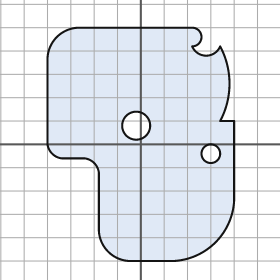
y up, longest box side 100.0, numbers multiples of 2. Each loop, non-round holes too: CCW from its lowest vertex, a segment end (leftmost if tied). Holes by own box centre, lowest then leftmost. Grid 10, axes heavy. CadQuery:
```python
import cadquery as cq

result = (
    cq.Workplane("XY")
    .moveTo(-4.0, -50.0)
    .lineTo(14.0, -50.0)
    .threePointArc((32.0, -42.0), (40.0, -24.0))
    .lineTo(40.0, 10.0)
    .lineTo(34.0, 10.0)
    .threePointArc((38.0, 26.0), (34.0, 42.0))
    .threePointArc((28.0, 38.0), (22.0, 42.0))
    .threePointArc((26.0, 46.0), (22.0, 50.0))
    .lineTo(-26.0, 50.0)
    .threePointArc((-36.0, 46.0), (-40.0, 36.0))
    .lineTo(-40.0, 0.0)
    .threePointArc((-38.0, -4.0), (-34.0, -6.0))
    .lineTo(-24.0, -6.0)
    .threePointArc((-20.0, -8.0), (-18.0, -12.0))
    .lineTo(-18.0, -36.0)
    .threePointArc((-14.0, -46.0), (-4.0, -50.0))
    .close()
    .moveTo(30.0, -4.0)
    .circle(4.0)
    .moveTo(-2.0, 8.0)
    .circle(6.0)
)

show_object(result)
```